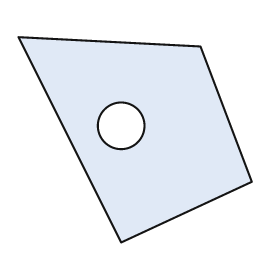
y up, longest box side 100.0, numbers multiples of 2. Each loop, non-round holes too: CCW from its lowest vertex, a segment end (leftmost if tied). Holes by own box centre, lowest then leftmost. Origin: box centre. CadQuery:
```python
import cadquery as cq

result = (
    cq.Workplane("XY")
    .moveTo(-6.0, -44.0)
    .lineTo(50.0, -18.0)
    .lineTo(28.0, 40.0)
    .lineTo(-50.0, 44.0)
    .close()
    .moveTo(-6.0, 6.0)
    .circle(10.0)
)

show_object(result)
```